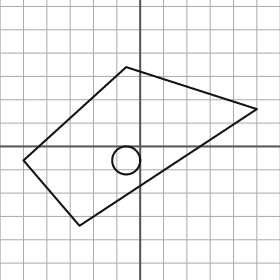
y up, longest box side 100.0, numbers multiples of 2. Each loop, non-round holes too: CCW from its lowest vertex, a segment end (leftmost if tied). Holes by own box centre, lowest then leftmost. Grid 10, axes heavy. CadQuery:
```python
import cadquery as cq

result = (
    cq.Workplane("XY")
    .moveTo(-26.0, -34.0)
    .lineTo(50.0, 16.0)
    .lineTo(-6.0, 34.0)
    .lineTo(-50.0, -6.0)
    .close()
    .moveTo(-6.0, -6.0)
    .circle(6.0)
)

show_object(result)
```